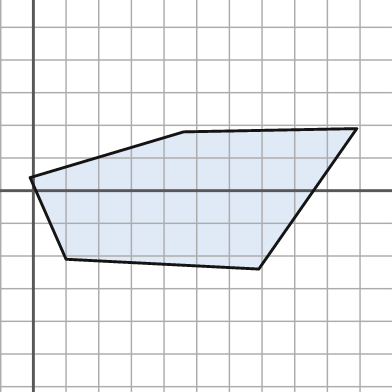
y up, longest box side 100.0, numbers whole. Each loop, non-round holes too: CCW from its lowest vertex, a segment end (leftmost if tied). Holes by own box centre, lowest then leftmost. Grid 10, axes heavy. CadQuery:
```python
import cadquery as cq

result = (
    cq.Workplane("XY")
    .moveTo(69.0, -24.0)
    .lineTo(99.0, 19.0)
    .lineTo(46.0, 18.0)
    .lineTo(-1.0, 4.0)
    .lineTo(10.0, -21.0)
    .close()
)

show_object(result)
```